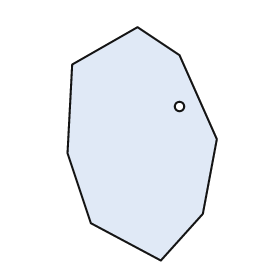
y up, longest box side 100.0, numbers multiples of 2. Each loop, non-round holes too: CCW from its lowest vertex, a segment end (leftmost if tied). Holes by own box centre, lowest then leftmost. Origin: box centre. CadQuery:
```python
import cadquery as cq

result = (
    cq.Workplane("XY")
    .moveTo(8.0, -50.0)
    .lineTo(26.0, -30.0)
    .lineTo(32.0, 2.0)
    .lineTo(16.0, 38.0)
    .lineTo(-2.0, 50.0)
    .lineTo(-30.0, 34.0)
    .lineTo(-32.0, -4.0)
    .lineTo(-22.0, -34.0)
    .close()
    .moveTo(16.0, 16.0)
    .circle(2.0)
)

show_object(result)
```